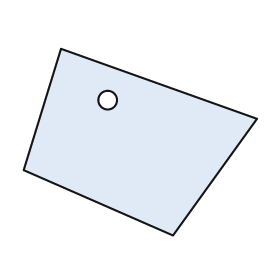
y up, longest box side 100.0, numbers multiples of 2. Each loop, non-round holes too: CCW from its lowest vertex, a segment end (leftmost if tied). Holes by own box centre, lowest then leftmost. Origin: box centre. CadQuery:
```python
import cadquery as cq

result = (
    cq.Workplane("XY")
    .moveTo(14.0, -40.0)
    .lineTo(50.0, 10.0)
    .lineTo(-34.0, 40.0)
    .lineTo(-50.0, -12.0)
    .close()
    .moveTo(-14.0, 18.0)
    .circle(4.0)
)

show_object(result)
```